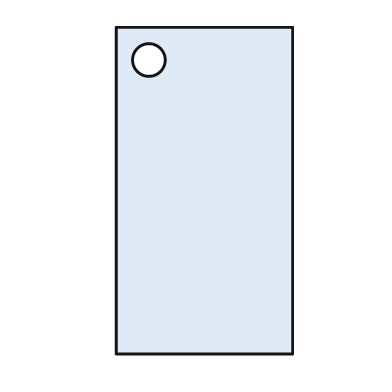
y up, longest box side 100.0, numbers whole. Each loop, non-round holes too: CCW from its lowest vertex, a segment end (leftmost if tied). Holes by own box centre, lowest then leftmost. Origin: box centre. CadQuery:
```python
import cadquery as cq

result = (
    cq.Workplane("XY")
    .moveTo(-27.0, -50.0)
    .lineTo(27.0, -50.0)
    .lineTo(27.0, 50.0)
    .lineTo(-27.0, 50.0)
    .close()
    .moveTo(-17.0, 40.0)
    .circle(5.0)
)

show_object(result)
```